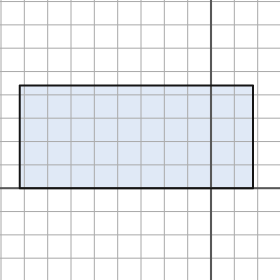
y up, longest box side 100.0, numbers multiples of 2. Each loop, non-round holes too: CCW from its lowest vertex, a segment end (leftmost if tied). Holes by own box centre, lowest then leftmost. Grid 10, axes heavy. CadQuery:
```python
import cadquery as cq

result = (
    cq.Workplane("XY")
    .moveTo(-82.0, 0.0)
    .lineTo(18.0, 0.0)
    .lineTo(18.0, 44.0)
    .lineTo(-82.0, 44.0)
    .close()
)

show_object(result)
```